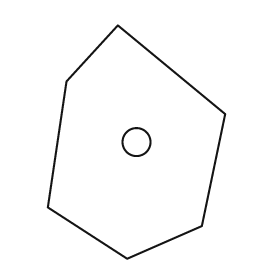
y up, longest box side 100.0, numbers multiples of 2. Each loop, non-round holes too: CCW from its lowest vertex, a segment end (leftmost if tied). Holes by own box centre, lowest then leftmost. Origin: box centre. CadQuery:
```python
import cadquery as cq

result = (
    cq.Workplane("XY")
    .moveTo(-4.0, -50.0)
    .lineTo(28.0, -36.0)
    .lineTo(38.0, 12.0)
    .lineTo(-8.0, 50.0)
    .lineTo(-30.0, 26.0)
    .lineTo(-38.0, -28.0)
    .close()
    .moveTo(0.0, 0.0)
    .circle(6.0)
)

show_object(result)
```